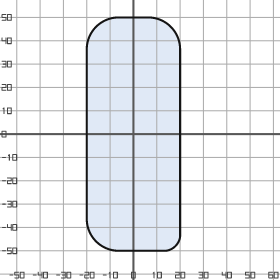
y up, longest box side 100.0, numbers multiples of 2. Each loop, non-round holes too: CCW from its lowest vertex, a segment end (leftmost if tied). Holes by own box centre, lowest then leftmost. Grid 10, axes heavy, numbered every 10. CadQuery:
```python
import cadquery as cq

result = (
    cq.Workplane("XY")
    .moveTo(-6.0, -50.0)
    .lineTo(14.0, -50.0)
    .threePointArc((18.0, -48.0), (20.0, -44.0))
    .lineTo(20.0, 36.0)
    .threePointArc((16.0, 46.0), (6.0, 50.0))
    .lineTo(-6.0, 50.0)
    .threePointArc((-16.0, 46.0), (-20.0, 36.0))
    .lineTo(-20.0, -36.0)
    .threePointArc((-16.0, -46.0), (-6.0, -50.0))
    .close()
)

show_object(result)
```